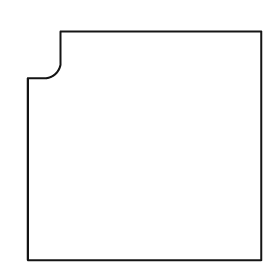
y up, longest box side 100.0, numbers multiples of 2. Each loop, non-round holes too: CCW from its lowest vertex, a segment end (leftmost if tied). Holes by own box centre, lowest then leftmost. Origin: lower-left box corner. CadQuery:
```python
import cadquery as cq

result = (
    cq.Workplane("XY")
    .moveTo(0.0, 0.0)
    .lineTo(100.0, 0.0)
    .lineTo(100.0, 98.0)
    .lineTo(14.0, 98.0)
    .lineTo(14.0, 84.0)
    .threePointArc((12.0, 80.0), (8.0, 78.0))
    .lineTo(0.0, 78.0)
    .close()
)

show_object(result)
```